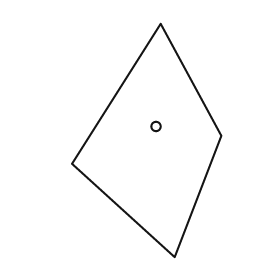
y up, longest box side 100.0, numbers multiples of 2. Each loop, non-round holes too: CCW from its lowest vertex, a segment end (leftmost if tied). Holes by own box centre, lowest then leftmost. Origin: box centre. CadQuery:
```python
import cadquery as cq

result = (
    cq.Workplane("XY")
    .moveTo(12.0, -50.0)
    .lineTo(32.0, 2.0)
    .lineTo(6.0, 50.0)
    .lineTo(-32.0, -10.0)
    .close()
    .moveTo(4.0, 6.0)
    .circle(2.0)
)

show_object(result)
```